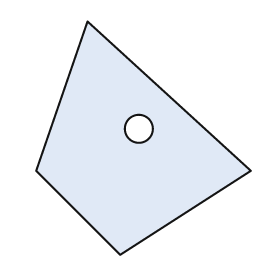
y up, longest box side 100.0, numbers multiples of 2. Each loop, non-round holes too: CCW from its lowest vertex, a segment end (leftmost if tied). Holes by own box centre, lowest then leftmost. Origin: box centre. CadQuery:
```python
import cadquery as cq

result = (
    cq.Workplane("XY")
    .moveTo(-10.0, -50.0)
    .lineTo(46.0, -14.0)
    .lineTo(-24.0, 50.0)
    .lineTo(-46.0, -14.0)
    .close()
    .moveTo(-2.0, 4.0)
    .circle(6.0)
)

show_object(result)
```